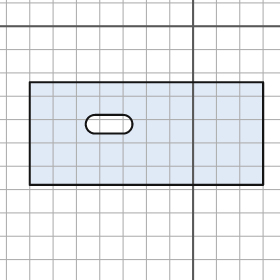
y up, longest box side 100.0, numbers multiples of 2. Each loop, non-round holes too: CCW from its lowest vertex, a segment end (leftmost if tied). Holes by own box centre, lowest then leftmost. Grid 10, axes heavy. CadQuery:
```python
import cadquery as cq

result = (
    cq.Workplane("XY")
    .moveTo(-70.0, -68.0)
    .lineTo(30.0, -68.0)
    .lineTo(30.0, -24.0)
    .lineTo(-70.0, -24.0)
    .close()
    .moveTo(-42.0, -46.0)
    .lineTo(-30.0, -46.0)
    .threePointArc((-26.0, -42.0), (-30.0, -38.0))
    .lineTo(-42.0, -38.0)
    .threePointArc((-46.0, -42.0), (-42.0, -46.0))
    .close()
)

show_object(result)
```